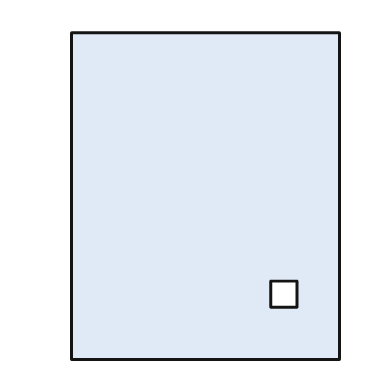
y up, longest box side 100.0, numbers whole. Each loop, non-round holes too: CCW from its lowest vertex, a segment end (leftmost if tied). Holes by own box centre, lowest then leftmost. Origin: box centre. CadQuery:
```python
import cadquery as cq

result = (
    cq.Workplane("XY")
    .moveTo(-41.0, -50.0)
    .lineTo(41.0, -50.0)
    .lineTo(41.0, 50.0)
    .lineTo(-41.0, 50.0)
    .close()
    .moveTo(20.0, -34.0)
    .lineTo(28.0, -34.0)
    .lineTo(28.0, -26.0)
    .lineTo(20.0, -26.0)
    .close()
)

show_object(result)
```